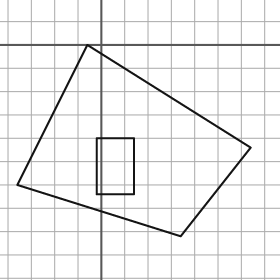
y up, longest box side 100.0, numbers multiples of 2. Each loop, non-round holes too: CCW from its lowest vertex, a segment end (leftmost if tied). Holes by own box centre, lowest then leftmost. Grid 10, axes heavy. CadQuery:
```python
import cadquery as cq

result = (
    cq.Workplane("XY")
    .moveTo(34.0, -82.0)
    .lineTo(64.0, -44.0)
    .lineTo(-6.0, 0.0)
    .lineTo(-36.0, -60.0)
    .close()
    .moveTo(-2.0, -64.0)
    .lineTo(14.0, -64.0)
    .lineTo(14.0, -40.0)
    .lineTo(-2.0, -40.0)
    .close()
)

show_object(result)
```